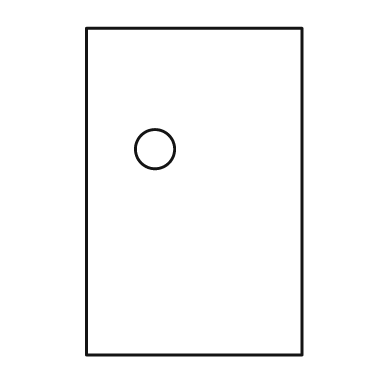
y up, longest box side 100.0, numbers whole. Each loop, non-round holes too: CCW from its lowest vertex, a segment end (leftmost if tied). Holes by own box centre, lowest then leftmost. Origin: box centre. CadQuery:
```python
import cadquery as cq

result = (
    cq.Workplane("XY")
    .moveTo(-33.0, -50.0)
    .lineTo(33.0, -50.0)
    .lineTo(33.0, 50.0)
    .lineTo(-33.0, 50.0)
    .close()
    .moveTo(-12.0, 13.0)
    .circle(6.0)
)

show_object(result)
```